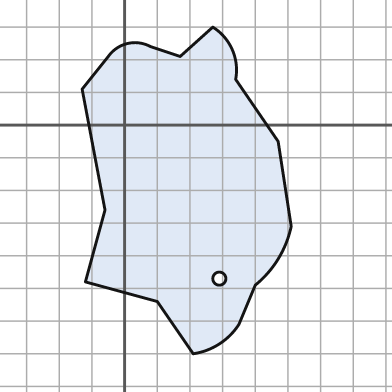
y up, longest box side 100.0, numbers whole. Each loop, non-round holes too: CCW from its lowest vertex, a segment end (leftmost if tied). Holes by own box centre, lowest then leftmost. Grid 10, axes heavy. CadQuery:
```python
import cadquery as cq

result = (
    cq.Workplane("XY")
    .moveTo(21.0, -70.0)
    .threePointArc((29.0, -67.0), (35.0, -61.0))
    .lineTo(40.0, -49.0)
    .threePointArc((47.0, -41.0), (51.0, -31.0))
    .lineTo(47.0, -5.0)
    .lineTo(34.0, 14.0)
    .threePointArc((33.0, 23.0), (27.0, 30.0))
    .lineTo(17.0, 21.0)
    .lineTo(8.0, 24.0)
    .threePointArc((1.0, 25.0), (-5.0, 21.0))
    .lineTo(-13.0, 11.0)
    .lineTo(-6.0, -26.0)
    .lineTo(-12.0, -48.0)
    .lineTo(10.0, -54.0)
    .close()
    .moveTo(29.0, -47.0)
    .circle(2.0)
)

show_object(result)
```